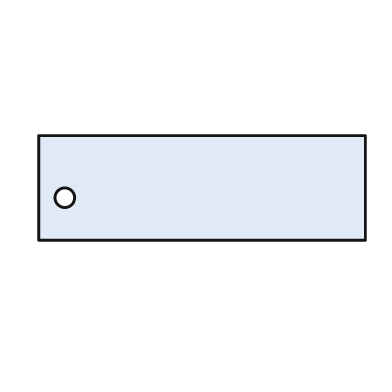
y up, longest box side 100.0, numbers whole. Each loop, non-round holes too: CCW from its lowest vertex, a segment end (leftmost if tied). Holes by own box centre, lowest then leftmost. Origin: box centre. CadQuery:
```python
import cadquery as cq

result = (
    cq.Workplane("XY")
    .moveTo(-50.0, -16.0)
    .lineTo(50.0, -16.0)
    .lineTo(50.0, 16.0)
    .lineTo(-50.0, 16.0)
    .close()
    .moveTo(-42.0, -3.0)
    .circle(3.0)
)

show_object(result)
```